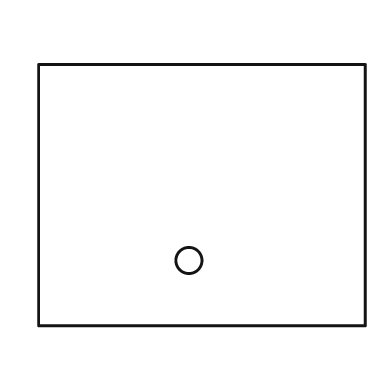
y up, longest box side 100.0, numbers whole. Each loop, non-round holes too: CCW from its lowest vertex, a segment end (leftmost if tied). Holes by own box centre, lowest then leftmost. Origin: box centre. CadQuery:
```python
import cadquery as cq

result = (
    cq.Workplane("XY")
    .moveTo(-50.0, -40.0)
    .lineTo(50.0, -40.0)
    .lineTo(50.0, 40.0)
    .lineTo(-50.0, 40.0)
    .close()
    .moveTo(-4.0, -20.0)
    .circle(4.0)
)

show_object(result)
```